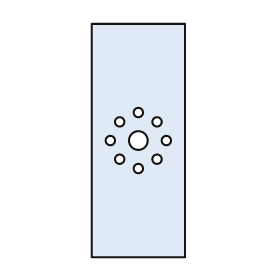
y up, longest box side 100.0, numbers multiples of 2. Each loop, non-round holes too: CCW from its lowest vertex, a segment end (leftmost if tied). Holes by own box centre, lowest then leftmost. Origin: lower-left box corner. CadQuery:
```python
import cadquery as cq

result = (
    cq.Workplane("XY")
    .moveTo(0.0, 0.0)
    .lineTo(40.0, 0.0)
    .lineTo(40.0, 100.0)
    .lineTo(0.0, 100.0)
    .close()
    .moveTo(20.0, 38.0)
    .circle(2.0)
    .moveTo(12.0, 42.0)
    .circle(2.0)
    .moveTo(28.0, 42.0)
    .circle(2.0)
    .moveTo(8.0, 50.0)
    .circle(2.0)
    .moveTo(20.0, 50.0)
    .circle(4.0)
    .moveTo(32.0, 50.0)
    .circle(2.0)
    .moveTo(12.0, 58.0)
    .circle(2.0)
    .moveTo(28.0, 58.0)
    .circle(2.0)
    .moveTo(20.0, 62.0)
    .circle(2.0)
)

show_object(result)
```